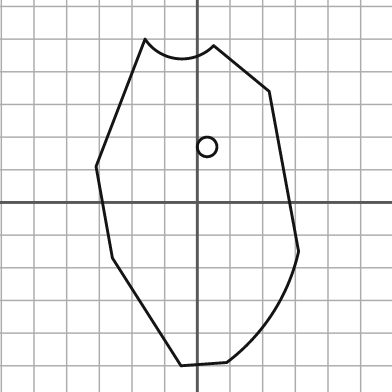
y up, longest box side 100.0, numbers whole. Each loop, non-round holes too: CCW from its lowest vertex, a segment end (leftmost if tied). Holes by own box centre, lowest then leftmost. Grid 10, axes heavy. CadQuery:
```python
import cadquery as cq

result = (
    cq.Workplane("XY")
    .moveTo(-5.0, -50.0)
    .lineTo(9.0, -49.0)
    .threePointArc((23.0, -34.0), (31.0, -15.0))
    .lineTo(22.0, 34.0)
    .lineTo(5.0, 48.0)
    .threePointArc((-6.0, 44.0), (-16.0, 50.0))
    .lineTo(-31.0, 11.0)
    .lineTo(-26.0, -17.0)
    .close()
    .moveTo(3.0, 17.0)
    .circle(3.0)
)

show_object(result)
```